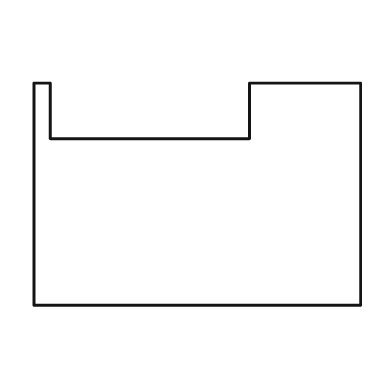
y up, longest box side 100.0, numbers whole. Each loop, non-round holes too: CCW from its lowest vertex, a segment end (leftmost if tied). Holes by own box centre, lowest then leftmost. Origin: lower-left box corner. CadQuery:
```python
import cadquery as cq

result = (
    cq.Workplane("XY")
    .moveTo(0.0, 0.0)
    .lineTo(100.0, 0.0)
    .lineTo(100.0, 68.0)
    .lineTo(66.0, 68.0)
    .lineTo(66.0, 51.0)
    .lineTo(5.0, 51.0)
    .lineTo(5.0, 68.0)
    .lineTo(0.0, 68.0)
    .close()
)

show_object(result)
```